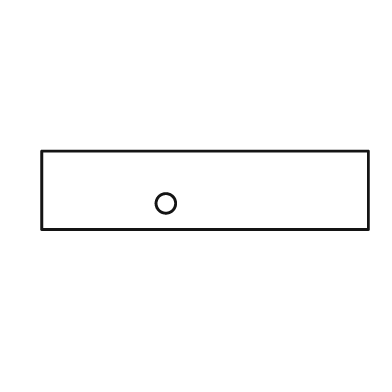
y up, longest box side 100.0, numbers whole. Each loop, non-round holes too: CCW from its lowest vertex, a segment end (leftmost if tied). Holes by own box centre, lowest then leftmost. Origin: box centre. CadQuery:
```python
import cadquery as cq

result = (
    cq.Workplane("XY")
    .moveTo(-50.0, -12.0)
    .lineTo(50.0, -12.0)
    .lineTo(50.0, 12.0)
    .lineTo(-50.0, 12.0)
    .close()
    .moveTo(-12.0, -4.0)
    .circle(3.0)
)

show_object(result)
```